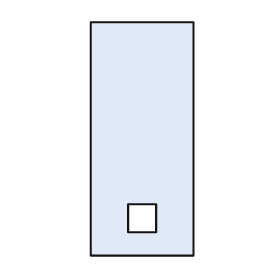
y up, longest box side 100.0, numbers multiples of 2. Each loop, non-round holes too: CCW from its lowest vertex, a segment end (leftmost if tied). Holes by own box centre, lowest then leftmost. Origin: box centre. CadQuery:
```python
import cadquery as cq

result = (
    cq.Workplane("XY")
    .moveTo(-22.0, -50.0)
    .lineTo(22.0, -50.0)
    .lineTo(22.0, 50.0)
    .lineTo(-22.0, 50.0)
    .close()
    .moveTo(-6.0, -40.0)
    .lineTo(6.0, -40.0)
    .lineTo(6.0, -28.0)
    .lineTo(-6.0, -28.0)
    .close()
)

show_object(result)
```